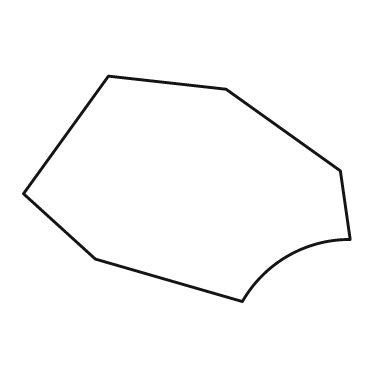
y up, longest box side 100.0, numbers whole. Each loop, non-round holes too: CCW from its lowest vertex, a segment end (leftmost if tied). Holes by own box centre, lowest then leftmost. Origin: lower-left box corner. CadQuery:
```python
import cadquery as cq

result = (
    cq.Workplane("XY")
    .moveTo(67.0, 0.0)
    .threePointArc((81.0, 14.0), (100.0, 19.0))
    .lineTo(97.0, 40.0)
    .lineTo(62.0, 65.0)
    .lineTo(26.0, 69.0)
    .lineTo(0.0, 33.0)
    .lineTo(22.0, 13.0)
    .close()
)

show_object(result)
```